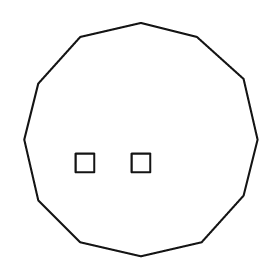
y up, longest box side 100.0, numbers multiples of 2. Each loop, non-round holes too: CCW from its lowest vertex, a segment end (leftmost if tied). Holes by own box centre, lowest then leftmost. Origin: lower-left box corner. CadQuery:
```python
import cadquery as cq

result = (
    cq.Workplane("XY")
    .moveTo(50.0, 0.0)
    .lineTo(76.0, 6.0)
    .lineTo(94.0, 26.0)
    .lineTo(100.0, 50.0)
    .lineTo(94.0, 76.0)
    .lineTo(74.0, 94.0)
    .lineTo(50.0, 100.0)
    .lineTo(24.0, 94.0)
    .lineTo(6.0, 74.0)
    .lineTo(0.0, 50.0)
    .lineTo(6.0, 24.0)
    .lineTo(24.0, 6.0)
    .close()
    .moveTo(22.0, 36.0)
    .lineTo(30.0, 36.0)
    .lineTo(30.0, 44.0)
    .lineTo(22.0, 44.0)
    .close()
    .moveTo(46.0, 36.0)
    .lineTo(54.0, 36.0)
    .lineTo(54.0, 44.0)
    .lineTo(46.0, 44.0)
    .close()
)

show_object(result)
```